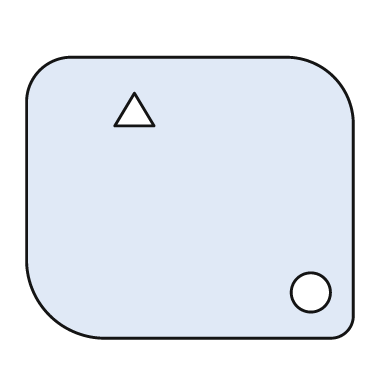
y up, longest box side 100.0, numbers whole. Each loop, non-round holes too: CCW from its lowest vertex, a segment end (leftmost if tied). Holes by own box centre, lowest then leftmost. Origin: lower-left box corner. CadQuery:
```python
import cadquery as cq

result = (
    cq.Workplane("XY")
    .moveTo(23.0, 0.0)
    .lineTo(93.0, 0.0)
    .threePointArc((98.0, 2.0), (100.0, 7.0))
    .lineTo(100.0, 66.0)
    .threePointArc((94.0, 80.0), (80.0, 86.0))
    .lineTo(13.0, 86.0)
    .threePointArc((4.0, 82.0), (0.0, 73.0))
    .lineTo(0.0, 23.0)
    .threePointArc((7.0, 7.0), (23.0, 0.0))
    .close()
    .moveTo(87.0, 14.0)
    .circle(6.0)
    .moveTo(27.0, 65.0)
    .lineTo(39.0, 65.0)
    .lineTo(33.0, 75.0)
    .close()
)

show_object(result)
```